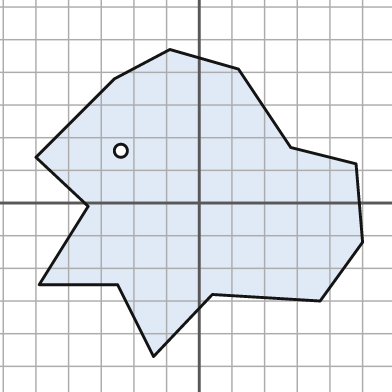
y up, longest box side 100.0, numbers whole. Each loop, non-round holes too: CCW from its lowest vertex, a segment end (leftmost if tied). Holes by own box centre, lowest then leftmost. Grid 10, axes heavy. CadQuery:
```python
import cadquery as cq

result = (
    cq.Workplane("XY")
    .moveTo(-14.0, -47.0)
    .lineTo(4.0, -28.0)
    .lineTo(37.0, -30.0)
    .lineTo(50.0, -12.0)
    .lineTo(48.0, 12.0)
    .lineTo(28.0, 17.0)
    .lineTo(12.0, 41.0)
    .lineTo(-9.0, 47.0)
    .lineTo(-26.0, 38.0)
    .lineTo(-50.0, 14.0)
    .lineTo(-34.0, -1.0)
    .lineTo(-49.0, -25.0)
    .lineTo(-25.0, -25.0)
    .close()
    .moveTo(-24.0, 16.0)
    .circle(2.0)
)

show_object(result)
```